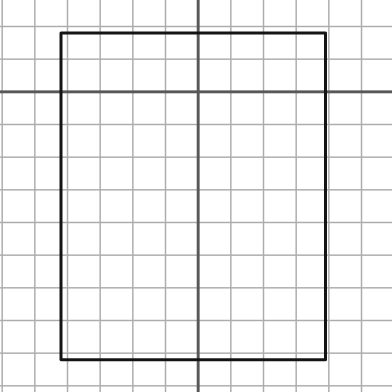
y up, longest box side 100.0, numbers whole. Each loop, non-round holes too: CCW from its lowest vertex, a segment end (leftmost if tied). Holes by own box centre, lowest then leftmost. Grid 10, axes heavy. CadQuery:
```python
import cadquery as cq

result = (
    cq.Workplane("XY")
    .moveTo(-42.0, -82.0)
    .lineTo(39.0, -82.0)
    .lineTo(39.0, 18.0)
    .lineTo(-42.0, 18.0)
    .close()
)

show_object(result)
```